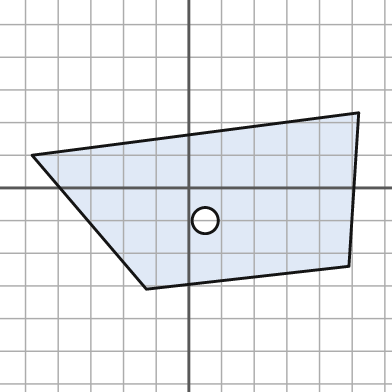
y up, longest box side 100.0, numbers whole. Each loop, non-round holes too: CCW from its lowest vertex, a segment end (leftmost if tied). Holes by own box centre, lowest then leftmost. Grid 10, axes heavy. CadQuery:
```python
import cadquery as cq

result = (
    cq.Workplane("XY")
    .moveTo(-13.0, -31.0)
    .lineTo(49.0, -24.0)
    .lineTo(52.0, 23.0)
    .lineTo(-48.0, 10.0)
    .close()
    .moveTo(5.0, -10.0)
    .circle(4.0)
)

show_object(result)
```